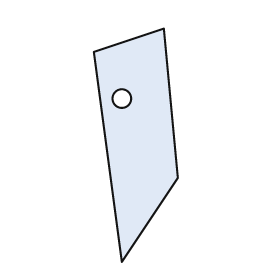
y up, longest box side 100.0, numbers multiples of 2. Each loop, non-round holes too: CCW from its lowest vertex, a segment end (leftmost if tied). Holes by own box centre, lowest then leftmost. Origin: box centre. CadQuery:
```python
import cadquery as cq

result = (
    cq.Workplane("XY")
    .moveTo(-6.0, -50.0)
    .lineTo(18.0, -14.0)
    .lineTo(12.0, 50.0)
    .lineTo(-18.0, 40.0)
    .close()
    .moveTo(-6.0, 20.0)
    .circle(4.0)
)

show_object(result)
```